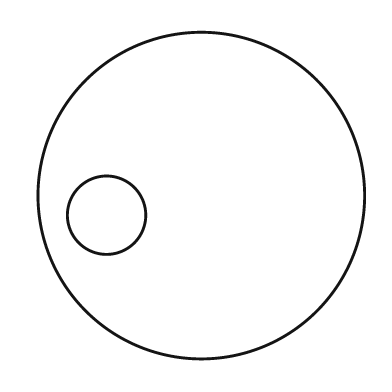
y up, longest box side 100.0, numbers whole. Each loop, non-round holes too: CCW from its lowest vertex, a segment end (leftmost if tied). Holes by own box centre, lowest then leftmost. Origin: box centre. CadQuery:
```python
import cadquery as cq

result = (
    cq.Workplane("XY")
    .moveTo(0.0, 0.0)
    .circle(50.0)
    .moveTo(-29.0, -6.0)
    .circle(12.0)
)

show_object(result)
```